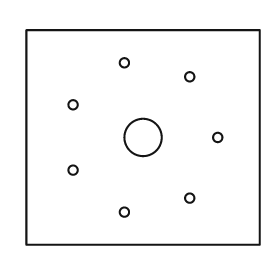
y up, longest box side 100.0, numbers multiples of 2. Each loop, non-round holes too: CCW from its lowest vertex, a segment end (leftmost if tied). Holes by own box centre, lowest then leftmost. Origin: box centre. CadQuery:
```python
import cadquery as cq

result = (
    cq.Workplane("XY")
    .moveTo(-50.0, -46.0)
    .lineTo(50.0, -46.0)
    .lineTo(50.0, 46.0)
    .lineTo(-50.0, 46.0)
    .close()
    .moveTo(-8.0, -32.0)
    .circle(2.0)
    .moveTo(20.0, -26.0)
    .circle(2.0)
    .moveTo(-30.0, -14.0)
    .circle(2.0)
    .moveTo(0.0, 0.0)
    .circle(8.0)
    .moveTo(32.0, 0.0)
    .circle(2.0)
    .moveTo(-30.0, 14.0)
    .circle(2.0)
    .moveTo(20.0, 26.0)
    .circle(2.0)
    .moveTo(-8.0, 32.0)
    .circle(2.0)
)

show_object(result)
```